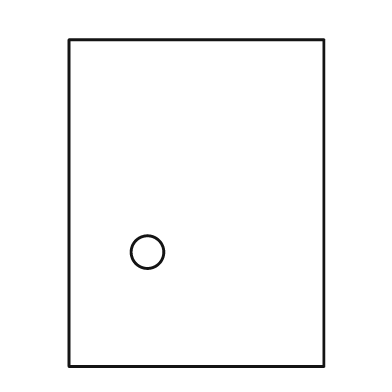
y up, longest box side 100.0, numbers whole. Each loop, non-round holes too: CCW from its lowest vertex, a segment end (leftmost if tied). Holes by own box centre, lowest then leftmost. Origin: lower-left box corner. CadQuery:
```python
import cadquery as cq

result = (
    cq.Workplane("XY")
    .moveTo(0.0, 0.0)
    .lineTo(78.0, 0.0)
    .lineTo(78.0, 100.0)
    .lineTo(0.0, 100.0)
    .close()
    .moveTo(24.0, 35.0)
    .circle(5.0)
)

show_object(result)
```